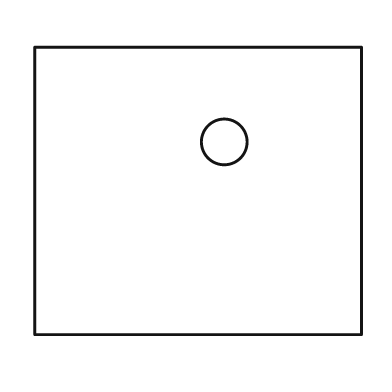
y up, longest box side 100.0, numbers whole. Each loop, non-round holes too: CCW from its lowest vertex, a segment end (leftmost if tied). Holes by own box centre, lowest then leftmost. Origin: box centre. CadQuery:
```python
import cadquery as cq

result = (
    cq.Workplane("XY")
    .moveTo(-50.0, -44.0)
    .lineTo(50.0, -44.0)
    .lineTo(50.0, 44.0)
    .lineTo(-50.0, 44.0)
    .close()
    .moveTo(8.0, 15.0)
    .circle(7.0)
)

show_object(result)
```